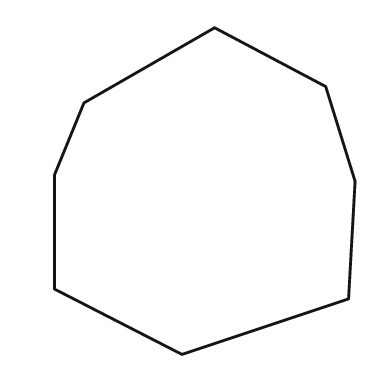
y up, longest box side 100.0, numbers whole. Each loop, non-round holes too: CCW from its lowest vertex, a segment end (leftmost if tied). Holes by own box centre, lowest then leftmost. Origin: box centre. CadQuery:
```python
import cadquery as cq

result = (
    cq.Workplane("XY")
    .moveTo(-7.0, -50.0)
    .lineTo(44.0, -33.0)
    .lineTo(46.0, 3.0)
    .lineTo(37.0, 32.0)
    .lineTo(3.0, 50.0)
    .lineTo(-37.0, 27.0)
    .lineTo(-46.0, 5.0)
    .lineTo(-46.0, -30.0)
    .close()
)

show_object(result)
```